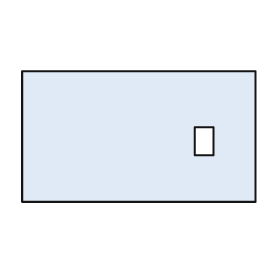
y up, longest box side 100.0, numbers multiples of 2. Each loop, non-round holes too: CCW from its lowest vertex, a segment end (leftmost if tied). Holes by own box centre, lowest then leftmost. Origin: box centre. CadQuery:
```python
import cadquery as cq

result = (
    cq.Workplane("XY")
    .moveTo(-50.0, -28.0)
    .lineTo(50.0, -28.0)
    .lineTo(50.0, 28.0)
    .lineTo(-50.0, 28.0)
    .close()
    .moveTo(24.0, -8.0)
    .lineTo(32.0, -8.0)
    .lineTo(32.0, 4.0)
    .lineTo(24.0, 4.0)
    .close()
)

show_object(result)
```